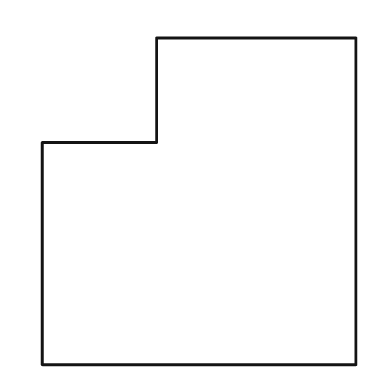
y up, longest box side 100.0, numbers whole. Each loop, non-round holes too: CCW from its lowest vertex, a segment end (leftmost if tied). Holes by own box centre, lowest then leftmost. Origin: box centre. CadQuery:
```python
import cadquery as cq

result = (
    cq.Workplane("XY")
    .moveTo(-48.0, -50.0)
    .lineTo(48.0, -50.0)
    .lineTo(48.0, 50.0)
    .lineTo(-13.0, 50.0)
    .lineTo(-13.0, 18.0)
    .lineTo(-48.0, 18.0)
    .close()
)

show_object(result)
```